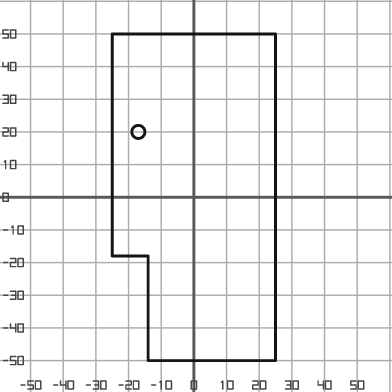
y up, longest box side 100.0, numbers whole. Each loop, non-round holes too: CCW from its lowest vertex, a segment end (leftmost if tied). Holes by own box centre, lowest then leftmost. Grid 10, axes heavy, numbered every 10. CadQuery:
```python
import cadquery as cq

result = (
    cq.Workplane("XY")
    .moveTo(-14.0, -50.0)
    .lineTo(25.0, -50.0)
    .lineTo(25.0, 50.0)
    .lineTo(-25.0, 50.0)
    .lineTo(-25.0, -18.0)
    .lineTo(-14.0, -18.0)
    .close()
    .moveTo(-17.0, 20.0)
    .circle(2.0)
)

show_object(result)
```